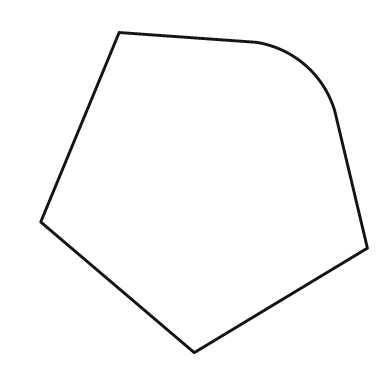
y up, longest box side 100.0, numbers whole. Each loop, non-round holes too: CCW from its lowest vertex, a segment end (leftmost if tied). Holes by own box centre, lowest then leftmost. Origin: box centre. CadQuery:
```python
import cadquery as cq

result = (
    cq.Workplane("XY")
    .moveTo(-3.0, -49.0)
    .lineTo(50.0, -17.0)
    .lineTo(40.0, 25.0)
    .threePointArc((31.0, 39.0), (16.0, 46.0))
    .lineTo(-26.0, 49.0)
    .lineTo(-50.0, -9.0)
    .close()
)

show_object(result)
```